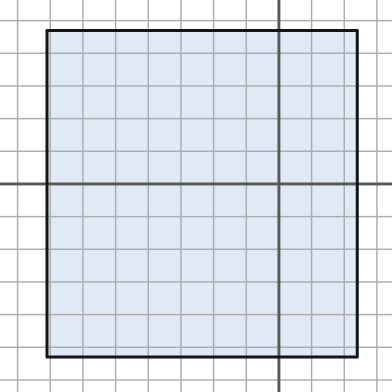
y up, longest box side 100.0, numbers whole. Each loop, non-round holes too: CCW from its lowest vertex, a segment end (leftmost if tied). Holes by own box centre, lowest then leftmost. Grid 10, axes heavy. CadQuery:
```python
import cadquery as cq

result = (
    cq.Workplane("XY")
    .moveTo(-71.0, -53.0)
    .lineTo(24.0, -53.0)
    .lineTo(24.0, 47.0)
    .lineTo(-71.0, 47.0)
    .close()
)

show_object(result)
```